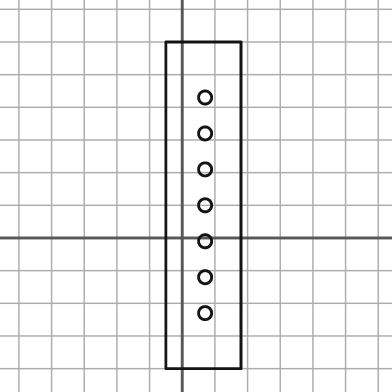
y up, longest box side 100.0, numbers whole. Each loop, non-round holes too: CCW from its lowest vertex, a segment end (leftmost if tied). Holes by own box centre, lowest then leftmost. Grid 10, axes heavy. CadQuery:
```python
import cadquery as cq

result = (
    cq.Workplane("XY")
    .moveTo(-5.0, -40.0)
    .lineTo(18.0, -40.0)
    .lineTo(18.0, 60.0)
    .lineTo(-5.0, 60.0)
    .close()
    .moveTo(7.0, -23.0)
    .circle(2.0)
    .moveTo(7.0, -12.0)
    .circle(2.0)
    .moveTo(7.0, -1.0)
    .circle(2.0)
    .moveTo(7.0, 10.0)
    .circle(2.0)
    .moveTo(7.0, 21.0)
    .circle(2.0)
    .moveTo(7.0, 32.0)
    .circle(2.0)
    .moveTo(7.0, 43.0)
    .circle(2.0)
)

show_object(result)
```